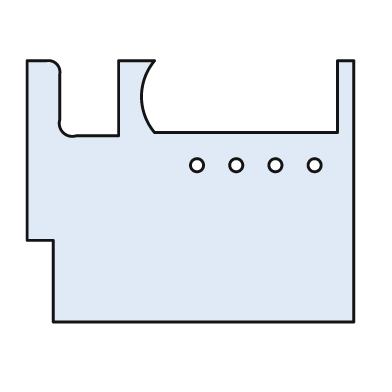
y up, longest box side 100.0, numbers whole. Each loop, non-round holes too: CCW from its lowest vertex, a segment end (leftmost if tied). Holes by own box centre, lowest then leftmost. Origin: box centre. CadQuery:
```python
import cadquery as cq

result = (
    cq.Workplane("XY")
    .moveTo(-42.0, -40.0)
    .lineTo(50.0, -40.0)
    .lineTo(50.0, 40.0)
    .lineTo(45.0, 40.0)
    .lineTo(45.0, 18.0)
    .lineTo(-11.0, 18.0)
    .threePointArc((-15.0, 29.0), (-11.0, 40.0))
    .lineTo(-22.0, 40.0)
    .lineTo(-22.0, 17.0)
    .lineTo(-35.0, 17.0)
    .threePointArc((-39.0, 18.0), (-40.0, 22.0))
    .lineTo(-40.0, 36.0)
    .threePointArc((-41.0, 39.0), (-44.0, 40.0))
    .lineTo(-50.0, 40.0)
    .lineTo(-50.0, -15.0)
    .lineTo(-42.0, -15.0)
    .close()
    .moveTo(2.0, 8.0)
    .circle(2.0)
    .moveTo(14.0, 8.0)
    .circle(2.0)
    .moveTo(26.0, 8.0)
    .circle(2.0)
    .moveTo(38.0, 8.0)
    .circle(2.0)
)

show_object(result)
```